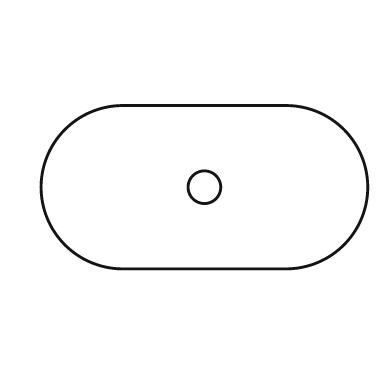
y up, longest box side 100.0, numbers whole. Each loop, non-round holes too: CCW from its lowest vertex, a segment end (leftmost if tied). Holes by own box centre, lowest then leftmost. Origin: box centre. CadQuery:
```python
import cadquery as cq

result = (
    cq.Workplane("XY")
    .moveTo(-25.0, -25.0)
    .lineTo(25.0, -25.0)
    .threePointArc((50.0, 0.0), (25.0, 25.0))
    .lineTo(-25.0, 25.0)
    .threePointArc((-50.0, 0.0), (-25.0, -25.0))
    .close()
    .moveTo(0.0, 0.0)
    .circle(5.0)
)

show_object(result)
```